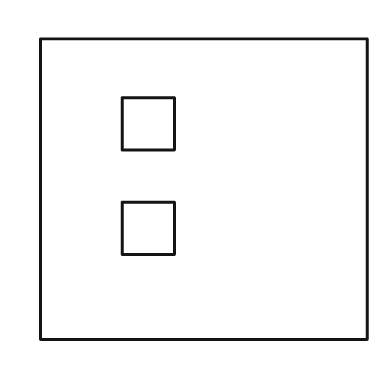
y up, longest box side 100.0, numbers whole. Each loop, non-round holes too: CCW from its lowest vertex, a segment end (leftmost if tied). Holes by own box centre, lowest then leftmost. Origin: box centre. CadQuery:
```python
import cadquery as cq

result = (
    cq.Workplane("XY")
    .moveTo(-50.0, -46.0)
    .lineTo(50.0, -46.0)
    .lineTo(50.0, 46.0)
    .lineTo(-50.0, 46.0)
    .close()
    .moveTo(-25.0, -20.0)
    .lineTo(-9.0, -20.0)
    .lineTo(-9.0, -4.0)
    .lineTo(-25.0, -4.0)
    .close()
    .moveTo(-25.0, 12.0)
    .lineTo(-9.0, 12.0)
    .lineTo(-9.0, 28.0)
    .lineTo(-25.0, 28.0)
    .close()
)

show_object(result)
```